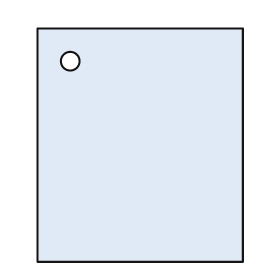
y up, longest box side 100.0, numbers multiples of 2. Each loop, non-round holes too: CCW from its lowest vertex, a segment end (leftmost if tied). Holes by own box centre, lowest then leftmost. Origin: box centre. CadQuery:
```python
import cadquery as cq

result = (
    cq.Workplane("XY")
    .moveTo(-44.0, -50.0)
    .lineTo(44.0, -50.0)
    .lineTo(44.0, 50.0)
    .lineTo(-44.0, 50.0)
    .close()
    .moveTo(-30.0, 36.0)
    .circle(4.0)
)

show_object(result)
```